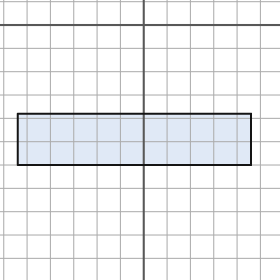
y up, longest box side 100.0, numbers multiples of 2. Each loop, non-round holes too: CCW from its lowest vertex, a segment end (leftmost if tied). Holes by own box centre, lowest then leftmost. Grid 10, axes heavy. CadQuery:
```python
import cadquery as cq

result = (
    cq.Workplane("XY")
    .moveTo(-54.0, -60.0)
    .lineTo(46.0, -60.0)
    .lineTo(46.0, -38.0)
    .lineTo(-54.0, -38.0)
    .close()
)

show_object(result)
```